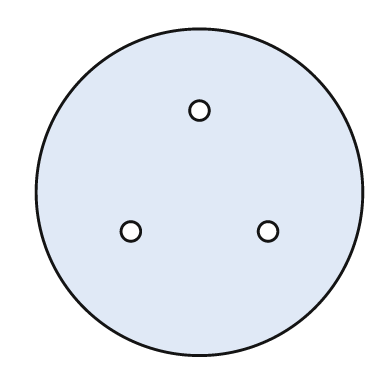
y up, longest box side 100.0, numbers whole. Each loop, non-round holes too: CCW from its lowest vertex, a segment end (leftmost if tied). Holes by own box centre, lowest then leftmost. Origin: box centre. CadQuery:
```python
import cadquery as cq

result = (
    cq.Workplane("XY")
    .moveTo(0.0, 0.0)
    .circle(50.0)
    .moveTo(-21.0, -12.0)
    .circle(3.0)
    .moveTo(21.0, -12.0)
    .circle(3.0)
    .moveTo(0.0, 25.0)
    .circle(3.0)
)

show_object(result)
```